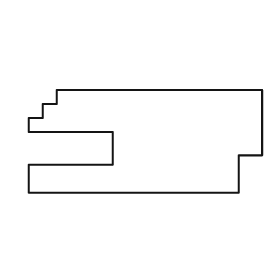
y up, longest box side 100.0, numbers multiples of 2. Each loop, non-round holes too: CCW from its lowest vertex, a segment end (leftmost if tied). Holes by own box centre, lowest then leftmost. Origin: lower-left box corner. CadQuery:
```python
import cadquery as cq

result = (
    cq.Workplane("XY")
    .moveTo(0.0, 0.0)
    .lineTo(90.0, 0.0)
    .lineTo(90.0, 16.0)
    .lineTo(100.0, 16.0)
    .lineTo(100.0, 44.0)
    .lineTo(12.0, 44.0)
    .lineTo(12.0, 38.0)
    .lineTo(6.0, 38.0)
    .lineTo(6.0, 32.0)
    .lineTo(0.0, 32.0)
    .lineTo(0.0, 26.0)
    .lineTo(36.0, 26.0)
    .lineTo(36.0, 12.0)
    .lineTo(0.0, 12.0)
    .close()
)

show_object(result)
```